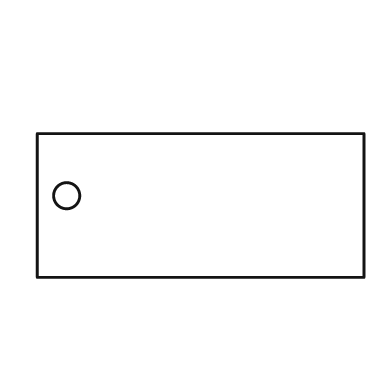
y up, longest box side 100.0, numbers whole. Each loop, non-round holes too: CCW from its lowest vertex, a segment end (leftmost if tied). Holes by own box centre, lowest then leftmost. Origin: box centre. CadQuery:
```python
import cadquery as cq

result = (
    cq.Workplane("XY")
    .moveTo(-50.0, -22.0)
    .lineTo(50.0, -22.0)
    .lineTo(50.0, 22.0)
    .lineTo(-50.0, 22.0)
    .close()
    .moveTo(-41.0, 3.0)
    .circle(4.0)
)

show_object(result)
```